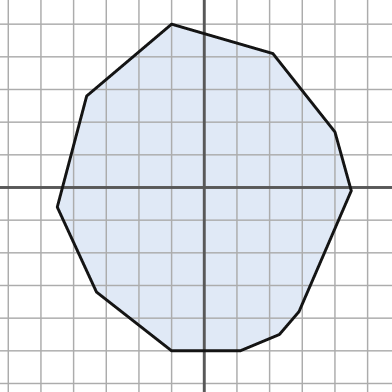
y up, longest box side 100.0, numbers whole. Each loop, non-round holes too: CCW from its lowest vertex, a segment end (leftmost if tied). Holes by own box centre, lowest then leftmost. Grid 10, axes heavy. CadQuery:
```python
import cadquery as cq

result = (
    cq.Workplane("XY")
    .moveTo(-10.0, -50.0)
    .lineTo(11.0, -50.0)
    .lineTo(23.0, -45.0)
    .lineTo(29.0, -38.0)
    .lineTo(45.0, -1.0)
    .lineTo(40.0, 17.0)
    .lineTo(21.0, 41.0)
    .lineTo(-10.0, 50.0)
    .lineTo(-36.0, 28.0)
    .lineTo(-45.0, -6.0)
    .lineTo(-33.0, -32.0)
    .close()
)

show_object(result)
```